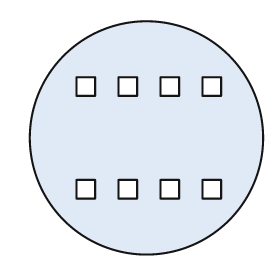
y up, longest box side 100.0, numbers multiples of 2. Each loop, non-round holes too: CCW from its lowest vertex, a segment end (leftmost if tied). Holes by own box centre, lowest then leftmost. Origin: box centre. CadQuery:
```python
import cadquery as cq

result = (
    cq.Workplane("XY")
    .moveTo(0.0, 0.0)
    .circle(50.0)
    .moveTo(-30.0, -26.0)
    .lineTo(-22.0, -26.0)
    .lineTo(-22.0, -18.0)
    .lineTo(-30.0, -18.0)
    .close()
    .moveTo(-12.0, -26.0)
    .lineTo(-4.0, -26.0)
    .lineTo(-4.0, -18.0)
    .lineTo(-12.0, -18.0)
    .close()
    .moveTo(6.0, -26.0)
    .lineTo(14.0, -26.0)
    .lineTo(14.0, -18.0)
    .lineTo(6.0, -18.0)
    .close()
    .moveTo(24.0, -26.0)
    .lineTo(32.0, -26.0)
    .lineTo(32.0, -18.0)
    .lineTo(24.0, -18.0)
    .close()
    .moveTo(-30.0, 18.0)
    .lineTo(-22.0, 18.0)
    .lineTo(-22.0, 26.0)
    .lineTo(-30.0, 26.0)
    .close()
    .moveTo(-12.0, 18.0)
    .lineTo(-4.0, 18.0)
    .lineTo(-4.0, 26.0)
    .lineTo(-12.0, 26.0)
    .close()
    .moveTo(6.0, 18.0)
    .lineTo(14.0, 18.0)
    .lineTo(14.0, 26.0)
    .lineTo(6.0, 26.0)
    .close()
    .moveTo(24.0, 18.0)
    .lineTo(32.0, 18.0)
    .lineTo(32.0, 26.0)
    .lineTo(24.0, 26.0)
    .close()
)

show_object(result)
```